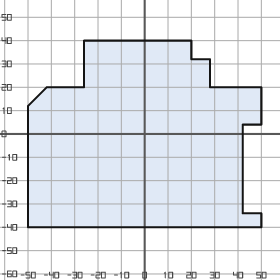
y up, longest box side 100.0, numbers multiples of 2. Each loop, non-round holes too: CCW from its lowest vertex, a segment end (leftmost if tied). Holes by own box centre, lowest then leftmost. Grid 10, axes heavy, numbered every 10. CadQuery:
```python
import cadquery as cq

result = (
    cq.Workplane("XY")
    .moveTo(-50.0, -40.0)
    .lineTo(50.0, -40.0)
    .lineTo(50.0, -34.0)
    .lineTo(42.0, -34.0)
    .lineTo(42.0, 4.0)
    .lineTo(50.0, 4.0)
    .lineTo(50.0, 20.0)
    .lineTo(28.0, 20.0)
    .lineTo(28.0, 32.0)
    .lineTo(20.0, 32.0)
    .lineTo(20.0, 40.0)
    .lineTo(-26.0, 40.0)
    .lineTo(-26.0, 20.0)
    .lineTo(-42.0, 20.0)
    .lineTo(-50.0, 12.0)
    .close()
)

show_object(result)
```